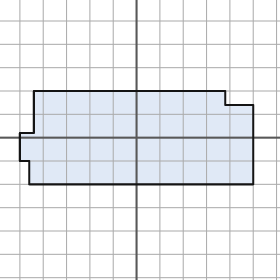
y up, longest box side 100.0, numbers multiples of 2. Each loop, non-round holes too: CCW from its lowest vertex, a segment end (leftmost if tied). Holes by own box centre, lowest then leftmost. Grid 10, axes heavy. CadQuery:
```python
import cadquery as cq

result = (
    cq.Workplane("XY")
    .moveTo(-46.0, -20.0)
    .lineTo(50.0, -20.0)
    .lineTo(50.0, 14.0)
    .lineTo(38.0, 14.0)
    .lineTo(38.0, 20.0)
    .lineTo(-44.0, 20.0)
    .lineTo(-44.0, 2.0)
    .lineTo(-50.0, 2.0)
    .lineTo(-50.0, -10.0)
    .lineTo(-46.0, -10.0)
    .close()
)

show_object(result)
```